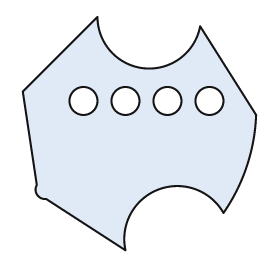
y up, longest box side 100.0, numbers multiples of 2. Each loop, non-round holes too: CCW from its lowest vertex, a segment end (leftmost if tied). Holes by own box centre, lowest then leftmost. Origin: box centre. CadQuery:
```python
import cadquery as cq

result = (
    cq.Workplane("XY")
    .moveTo(-6.0, -50.0)
    .threePointArc((8.0, -24.0), (36.0, -34.0))
    .threePointArc((46.0, -14.0), (50.0, 8.0))
    .lineTo(26.0, 46.0)
    .threePointArc((2.0, 28.0), (-18.0, 50.0))
    .lineTo(-50.0, 18.0)
    .lineTo(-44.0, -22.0)
    .threePointArc((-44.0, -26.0), (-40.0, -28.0))
    .close()
    .moveTo(-24.0, 14.0)
    .circle(6.0)
    .moveTo(-6.0, 14.0)
    .circle(6.0)
    .moveTo(12.0, 14.0)
    .circle(6.0)
    .moveTo(30.0, 14.0)
    .circle(6.0)
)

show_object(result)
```